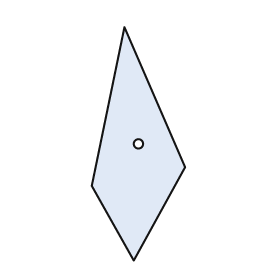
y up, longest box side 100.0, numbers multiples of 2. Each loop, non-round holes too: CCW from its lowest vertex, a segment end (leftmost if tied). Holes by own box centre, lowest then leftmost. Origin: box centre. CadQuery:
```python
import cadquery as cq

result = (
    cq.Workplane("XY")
    .moveTo(-2.0, -50.0)
    .lineTo(20.0, -10.0)
    .lineTo(-6.0, 50.0)
    .lineTo(-20.0, -18.0)
    .close()
    .moveTo(0.0, 0.0)
    .circle(2.0)
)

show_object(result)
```